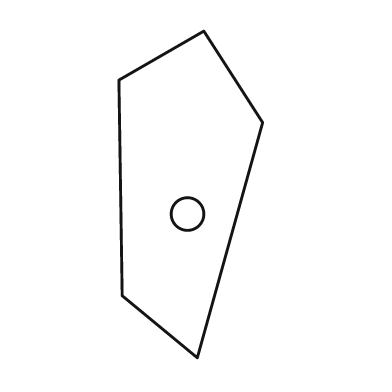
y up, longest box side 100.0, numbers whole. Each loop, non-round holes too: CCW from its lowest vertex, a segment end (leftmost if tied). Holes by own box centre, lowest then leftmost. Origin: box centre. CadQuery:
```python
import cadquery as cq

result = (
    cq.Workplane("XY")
    .moveTo(2.0, -50.0)
    .lineTo(22.0, 22.0)
    .lineTo(4.0, 50.0)
    .lineTo(-22.0, 35.0)
    .lineTo(-21.0, -31.0)
    .close()
    .moveTo(-1.0, -6.0)
    .circle(5.0)
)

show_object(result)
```